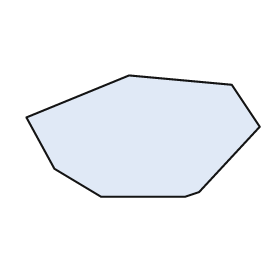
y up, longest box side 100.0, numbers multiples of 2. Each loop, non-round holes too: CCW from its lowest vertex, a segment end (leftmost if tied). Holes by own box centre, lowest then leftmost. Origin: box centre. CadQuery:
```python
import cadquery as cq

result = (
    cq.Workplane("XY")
    .moveTo(-18.0, -26.0)
    .lineTo(18.0, -26.0)
    .lineTo(24.0, -24.0)
    .lineTo(50.0, 4.0)
    .lineTo(38.0, 22.0)
    .lineTo(-6.0, 26.0)
    .lineTo(-50.0, 8.0)
    .lineTo(-38.0, -14.0)
    .close()
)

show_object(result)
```